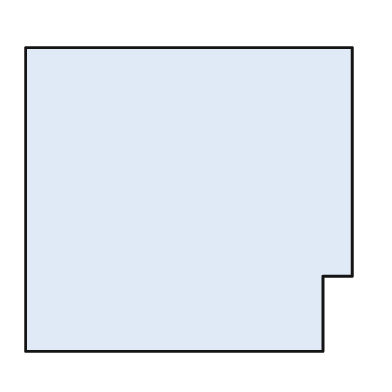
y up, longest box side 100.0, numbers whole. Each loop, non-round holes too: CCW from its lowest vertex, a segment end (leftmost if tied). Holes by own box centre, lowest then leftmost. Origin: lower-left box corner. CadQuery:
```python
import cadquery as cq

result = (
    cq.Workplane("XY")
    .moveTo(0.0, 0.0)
    .lineTo(91.0, 0.0)
    .lineTo(91.0, 23.0)
    .lineTo(100.0, 23.0)
    .lineTo(100.0, 93.0)
    .lineTo(0.0, 93.0)
    .close()
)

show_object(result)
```